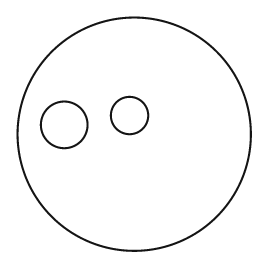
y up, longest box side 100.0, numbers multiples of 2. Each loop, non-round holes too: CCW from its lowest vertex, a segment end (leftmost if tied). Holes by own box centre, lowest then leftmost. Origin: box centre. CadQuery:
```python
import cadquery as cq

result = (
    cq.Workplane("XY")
    .moveTo(0.0, 0.0)
    .circle(50.0)
    .moveTo(-30.0, 4.0)
    .circle(10.0)
    .moveTo(-2.0, 8.0)
    .circle(8.0)
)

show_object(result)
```